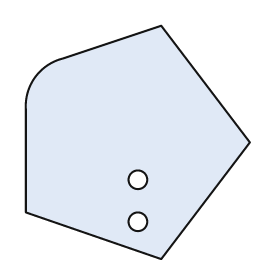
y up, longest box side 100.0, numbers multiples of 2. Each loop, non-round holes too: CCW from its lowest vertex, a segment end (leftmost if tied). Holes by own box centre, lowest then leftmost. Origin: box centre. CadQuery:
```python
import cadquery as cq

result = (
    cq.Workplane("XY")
    .moveTo(10.0, -50.0)
    .lineTo(48.0, 0.0)
    .lineTo(10.0, 50.0)
    .lineTo(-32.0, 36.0)
    .threePointArc((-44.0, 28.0), (-48.0, 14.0))
    .lineTo(-48.0, -30.0)
    .close()
    .moveTo(0.0, -34.0)
    .circle(4.0)
    .moveTo(0.0, -16.0)
    .circle(4.0)
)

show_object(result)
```